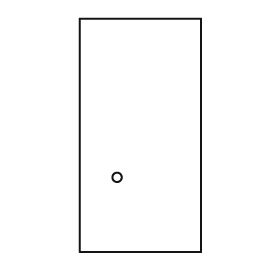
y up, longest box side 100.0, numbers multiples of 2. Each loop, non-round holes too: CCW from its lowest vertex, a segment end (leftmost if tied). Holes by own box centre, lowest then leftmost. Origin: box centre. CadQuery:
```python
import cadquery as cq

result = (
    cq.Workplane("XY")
    .moveTo(-26.0, -50.0)
    .lineTo(26.0, -50.0)
    .lineTo(26.0, 50.0)
    .lineTo(-26.0, 50.0)
    .close()
    .moveTo(-10.0, -18.0)
    .circle(2.0)
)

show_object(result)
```